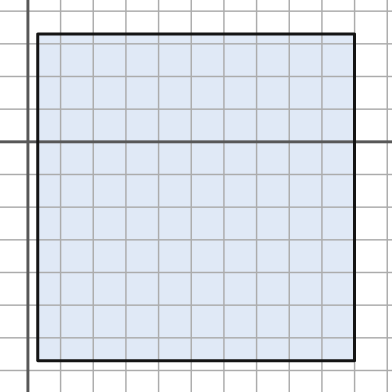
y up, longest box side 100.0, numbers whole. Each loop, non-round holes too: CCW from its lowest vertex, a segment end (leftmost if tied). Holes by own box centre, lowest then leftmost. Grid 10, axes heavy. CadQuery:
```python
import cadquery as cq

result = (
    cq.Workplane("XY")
    .moveTo(3.0, -67.0)
    .lineTo(100.0, -67.0)
    .lineTo(100.0, 33.0)
    .lineTo(3.0, 33.0)
    .close()
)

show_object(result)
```